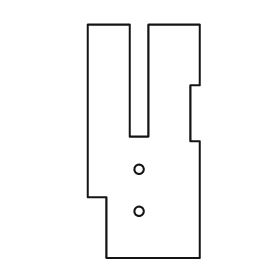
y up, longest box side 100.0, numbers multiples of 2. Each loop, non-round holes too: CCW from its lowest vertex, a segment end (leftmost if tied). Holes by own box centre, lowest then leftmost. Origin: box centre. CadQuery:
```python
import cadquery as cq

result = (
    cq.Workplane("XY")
    .moveTo(-16.0, -50.0)
    .lineTo(24.0, -50.0)
    .lineTo(24.0, 0.0)
    .lineTo(20.0, 0.0)
    .lineTo(20.0, 24.0)
    .lineTo(24.0, 24.0)
    .lineTo(24.0, 50.0)
    .lineTo(2.0, 50.0)
    .lineTo(2.0, 2.0)
    .lineTo(-6.0, 2.0)
    .lineTo(-6.0, 50.0)
    .lineTo(-24.0, 50.0)
    .lineTo(-24.0, -24.0)
    .lineTo(-16.0, -24.0)
    .close()
    .moveTo(-2.0, -30.0)
    .circle(2.0)
    .moveTo(-2.0, -12.0)
    .circle(2.0)
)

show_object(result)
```